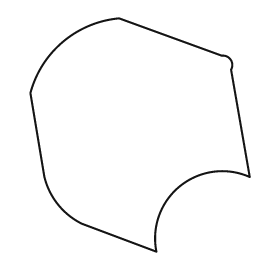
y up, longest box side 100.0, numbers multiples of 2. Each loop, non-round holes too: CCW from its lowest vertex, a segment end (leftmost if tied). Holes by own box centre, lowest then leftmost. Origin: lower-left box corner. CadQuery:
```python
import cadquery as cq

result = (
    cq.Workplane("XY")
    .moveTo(54.0, 0.0)
    .threePointArc((64.0, 28.0), (94.0, 32.0))
    .lineTo(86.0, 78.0)
    .threePointArc((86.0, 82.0), (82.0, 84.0))
    .lineTo(38.0, 100.0)
    .threePointArc((14.0, 90.0), (0.0, 68.0))
    .lineTo(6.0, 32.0)
    .threePointArc((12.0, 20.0), (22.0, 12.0))
    .close()
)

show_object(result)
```